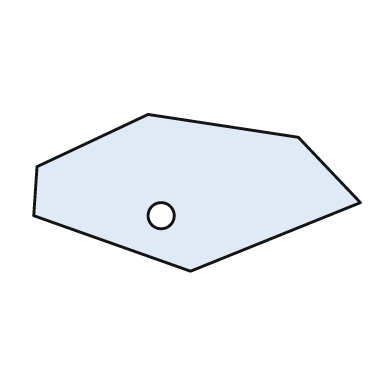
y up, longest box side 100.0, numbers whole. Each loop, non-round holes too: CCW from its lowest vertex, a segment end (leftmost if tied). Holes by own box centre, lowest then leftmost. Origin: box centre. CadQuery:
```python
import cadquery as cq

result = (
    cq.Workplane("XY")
    .moveTo(-2.0, -24.0)
    .lineTo(50.0, -3.0)
    .lineTo(31.0, 17.0)
    .lineTo(-15.0, 24.0)
    .lineTo(-49.0, 8.0)
    .lineTo(-50.0, -7.0)
    .close()
    .moveTo(-11.0, -7.0)
    .circle(4.0)
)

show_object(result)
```